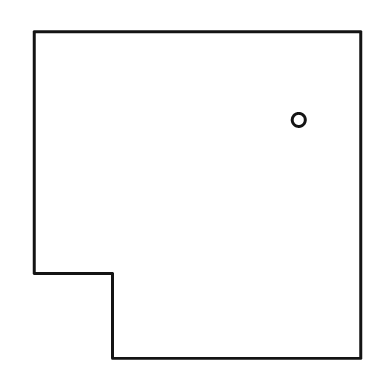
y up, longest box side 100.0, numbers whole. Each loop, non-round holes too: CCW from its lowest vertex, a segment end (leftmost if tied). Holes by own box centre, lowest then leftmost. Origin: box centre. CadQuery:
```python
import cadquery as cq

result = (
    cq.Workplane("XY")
    .moveTo(-26.0, -50.0)
    .lineTo(50.0, -50.0)
    .lineTo(50.0, 50.0)
    .lineTo(-50.0, 50.0)
    .lineTo(-50.0, -24.0)
    .lineTo(-26.0, -24.0)
    .close()
    .moveTo(31.0, 23.0)
    .circle(2.0)
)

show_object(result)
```